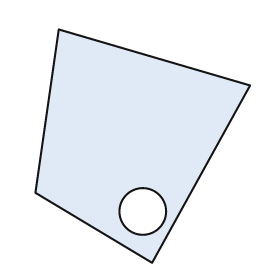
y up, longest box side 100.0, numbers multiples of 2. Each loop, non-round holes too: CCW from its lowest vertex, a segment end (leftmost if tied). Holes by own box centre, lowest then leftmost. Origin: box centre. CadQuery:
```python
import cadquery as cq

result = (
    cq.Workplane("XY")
    .moveTo(4.0, -50.0)
    .lineTo(46.0, 26.0)
    .lineTo(-36.0, 50.0)
    .lineTo(-46.0, -20.0)
    .close()
    .moveTo(0.0, -28.0)
    .circle(10.0)
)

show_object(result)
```